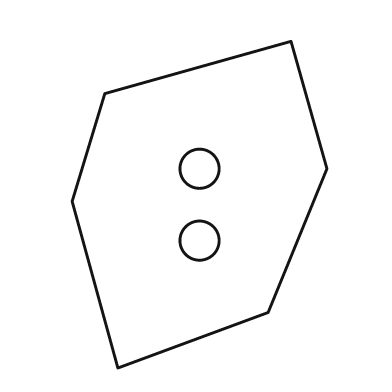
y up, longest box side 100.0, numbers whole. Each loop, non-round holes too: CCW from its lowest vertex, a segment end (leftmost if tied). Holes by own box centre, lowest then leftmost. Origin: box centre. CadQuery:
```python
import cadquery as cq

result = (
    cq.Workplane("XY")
    .moveTo(-25.0, -50.0)
    .lineTo(21.0, -33.0)
    .lineTo(39.0, 11.0)
    .lineTo(28.0, 50.0)
    .lineTo(-29.0, 34.0)
    .lineTo(-39.0, 1.0)
    .close()
    .moveTo(0.0, -11.0)
    .circle(6.0)
    .moveTo(0.0, 11.0)
    .circle(6.0)
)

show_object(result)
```